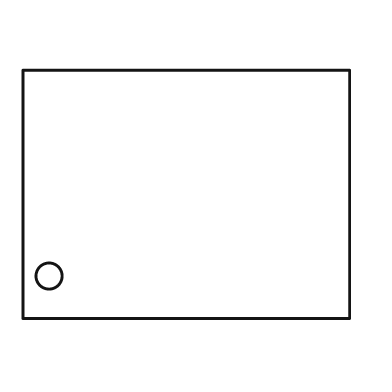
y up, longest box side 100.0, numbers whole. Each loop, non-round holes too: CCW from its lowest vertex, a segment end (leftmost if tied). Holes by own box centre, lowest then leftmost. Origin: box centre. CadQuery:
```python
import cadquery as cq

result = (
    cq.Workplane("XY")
    .moveTo(-50.0, -38.0)
    .lineTo(50.0, -38.0)
    .lineTo(50.0, 38.0)
    .lineTo(-50.0, 38.0)
    .close()
    .moveTo(-42.0, -25.0)
    .circle(4.0)
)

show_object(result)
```